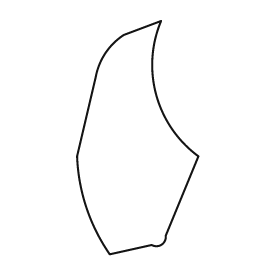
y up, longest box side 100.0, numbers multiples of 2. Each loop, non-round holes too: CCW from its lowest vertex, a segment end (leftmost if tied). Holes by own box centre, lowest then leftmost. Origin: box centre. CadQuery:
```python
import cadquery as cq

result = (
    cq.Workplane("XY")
    .moveTo(-12.0, -50.0)
    .lineTo(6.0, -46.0)
    .threePointArc((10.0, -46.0), (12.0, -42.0))
    .lineTo(26.0, -8.0)
    .threePointArc((8.0, 18.0), (10.0, 50.0))
    .lineTo(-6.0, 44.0)
    .threePointArc((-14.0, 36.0), (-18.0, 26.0))
    .lineTo(-26.0, -8.0)
    .threePointArc((-22.0, -30.0), (-12.0, -50.0))
    .close()
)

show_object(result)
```